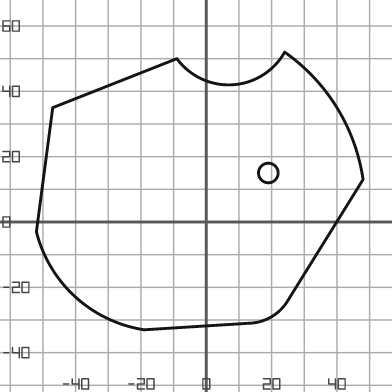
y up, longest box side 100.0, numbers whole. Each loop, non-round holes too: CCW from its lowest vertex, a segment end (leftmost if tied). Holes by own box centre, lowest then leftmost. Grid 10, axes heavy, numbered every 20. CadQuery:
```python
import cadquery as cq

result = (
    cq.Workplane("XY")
    .moveTo(-19.0, -33.0)
    .lineTo(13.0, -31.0)
    .threePointArc((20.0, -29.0), (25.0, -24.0))
    .lineTo(48.0, 13.0)
    .threePointArc((40.0, 35.0), (24.0, 52.0))
    .threePointArc((8.0, 42.0), (-9.0, 50.0))
    .lineTo(-47.0, 35.0)
    .lineTo(-52.0, -3.0)
    .threePointArc((-40.0, -23.0), (-19.0, -33.0))
    .close()
    .moveTo(19.0, 15.0)
    .circle(3.0)
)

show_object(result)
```